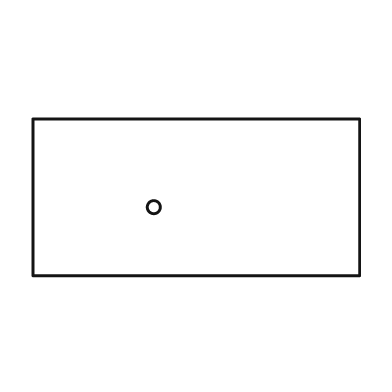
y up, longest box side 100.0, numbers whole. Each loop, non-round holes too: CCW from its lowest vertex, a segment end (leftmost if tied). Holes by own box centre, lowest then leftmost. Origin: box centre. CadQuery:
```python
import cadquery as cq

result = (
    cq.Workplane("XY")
    .moveTo(-50.0, -24.0)
    .lineTo(50.0, -24.0)
    .lineTo(50.0, 24.0)
    .lineTo(-50.0, 24.0)
    .close()
    .moveTo(-13.0, -3.0)
    .circle(2.0)
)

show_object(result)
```